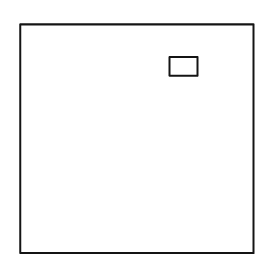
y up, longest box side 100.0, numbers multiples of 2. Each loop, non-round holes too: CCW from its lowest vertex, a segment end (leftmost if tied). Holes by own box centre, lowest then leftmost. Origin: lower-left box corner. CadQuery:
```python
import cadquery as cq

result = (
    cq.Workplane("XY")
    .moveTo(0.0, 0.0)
    .lineTo(100.0, 0.0)
    .lineTo(100.0, 98.0)
    .lineTo(0.0, 98.0)
    .close()
    .moveTo(64.0, 76.0)
    .lineTo(76.0, 76.0)
    .lineTo(76.0, 84.0)
    .lineTo(64.0, 84.0)
    .close()
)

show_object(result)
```